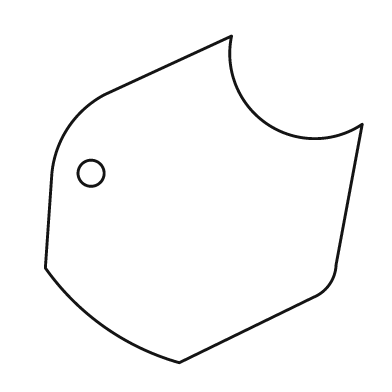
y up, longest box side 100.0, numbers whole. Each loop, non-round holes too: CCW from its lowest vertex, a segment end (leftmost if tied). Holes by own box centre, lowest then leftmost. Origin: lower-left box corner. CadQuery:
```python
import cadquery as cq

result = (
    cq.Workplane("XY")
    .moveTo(41.0, 0.0)
    .lineTo(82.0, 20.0)
    .threePointArc((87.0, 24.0), (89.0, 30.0))
    .lineTo(97.0, 73.0)
    .threePointArc((68.0, 73.0), (57.0, 100.0))
    .lineTo(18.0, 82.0)
    .threePointArc((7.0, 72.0), (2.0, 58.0))
    .lineTo(0.0, 29.0)
    .threePointArc((18.0, 11.0), (41.0, 0.0))
    .close()
    .moveTo(14.0, 58.0)
    .circle(4.0)
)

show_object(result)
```